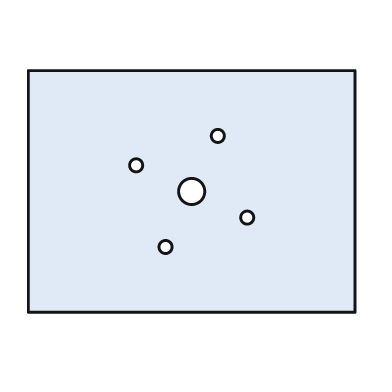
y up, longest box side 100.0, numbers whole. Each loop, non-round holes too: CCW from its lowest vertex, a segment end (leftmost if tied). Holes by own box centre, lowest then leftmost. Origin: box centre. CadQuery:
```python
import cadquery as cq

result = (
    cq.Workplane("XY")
    .moveTo(-50.0, -37.0)
    .lineTo(50.0, -37.0)
    .lineTo(50.0, 37.0)
    .lineTo(-50.0, 37.0)
    .close()
    .moveTo(-8.0, -17.0)
    .circle(2.0)
    .moveTo(17.0, -8.0)
    .circle(2.0)
    .moveTo(0.0, 0.0)
    .circle(4.0)
    .moveTo(-17.0, 8.0)
    .circle(2.0)
    .moveTo(8.0, 17.0)
    .circle(2.0)
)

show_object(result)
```